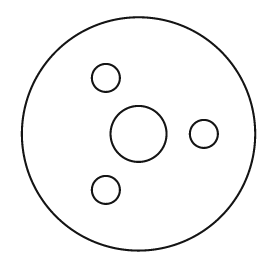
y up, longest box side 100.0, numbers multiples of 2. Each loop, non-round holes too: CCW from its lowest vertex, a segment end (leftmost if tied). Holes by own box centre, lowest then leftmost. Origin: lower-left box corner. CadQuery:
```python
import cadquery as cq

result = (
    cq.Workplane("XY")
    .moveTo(50.0, 50.0)
    .circle(50.0)
    .moveTo(36.0, 26.0)
    .circle(6.0)
    .moveTo(50.0, 50.0)
    .circle(12.0)
    .moveTo(78.0, 50.0)
    .circle(6.0)
    .moveTo(36.0, 74.0)
    .circle(6.0)
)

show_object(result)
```